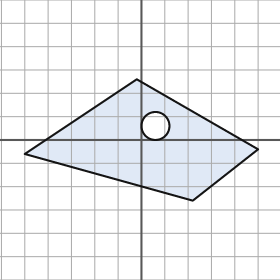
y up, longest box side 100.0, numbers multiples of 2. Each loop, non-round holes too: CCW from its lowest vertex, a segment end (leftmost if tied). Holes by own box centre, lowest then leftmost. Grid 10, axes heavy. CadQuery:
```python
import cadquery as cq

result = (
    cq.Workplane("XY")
    .moveTo(22.0, -26.0)
    .lineTo(50.0, -4.0)
    .lineTo(-2.0, 26.0)
    .lineTo(-50.0, -6.0)
    .close()
    .moveTo(6.0, 6.0)
    .circle(6.0)
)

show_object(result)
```